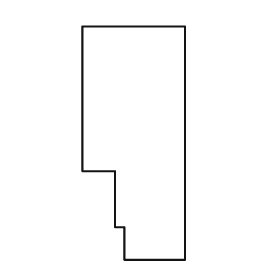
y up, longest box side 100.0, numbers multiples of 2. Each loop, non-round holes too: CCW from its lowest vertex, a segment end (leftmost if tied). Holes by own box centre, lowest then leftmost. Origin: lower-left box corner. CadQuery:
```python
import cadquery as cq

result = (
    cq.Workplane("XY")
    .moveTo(18.0, 0.0)
    .lineTo(44.0, 0.0)
    .lineTo(44.0, 100.0)
    .lineTo(0.0, 100.0)
    .lineTo(0.0, 38.0)
    .lineTo(14.0, 38.0)
    .lineTo(14.0, 14.0)
    .lineTo(18.0, 14.0)
    .close()
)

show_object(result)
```